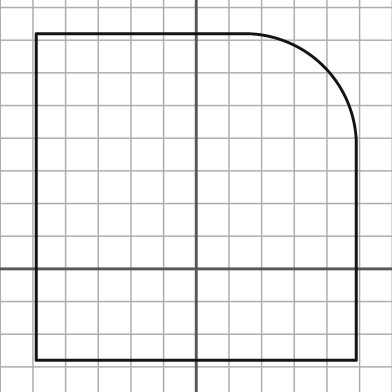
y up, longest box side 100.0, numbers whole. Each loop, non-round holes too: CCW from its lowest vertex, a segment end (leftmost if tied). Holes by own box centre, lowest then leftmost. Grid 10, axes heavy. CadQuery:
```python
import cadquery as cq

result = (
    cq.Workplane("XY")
    .moveTo(-49.0, -28.0)
    .lineTo(49.0, -28.0)
    .lineTo(49.0, 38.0)
    .threePointArc((39.0, 62.0), (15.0, 72.0))
    .lineTo(-49.0, 72.0)
    .close()
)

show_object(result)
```